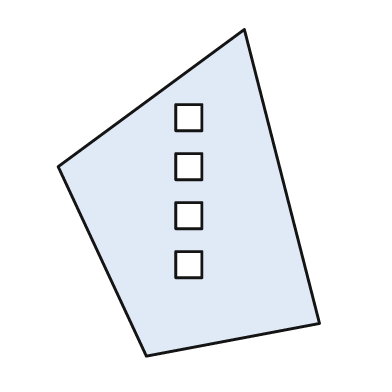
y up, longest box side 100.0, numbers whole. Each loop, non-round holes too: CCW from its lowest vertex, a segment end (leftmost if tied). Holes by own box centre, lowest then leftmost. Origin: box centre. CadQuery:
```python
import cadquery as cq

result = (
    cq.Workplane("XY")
    .moveTo(-13.0, -50.0)
    .lineTo(40.0, -40.0)
    .lineTo(17.0, 50.0)
    .lineTo(-40.0, 8.0)
    .close()
    .moveTo(-4.0, -26.0)
    .lineTo(4.0, -26.0)
    .lineTo(4.0, -18.0)
    .lineTo(-4.0, -18.0)
    .close()
    .moveTo(-4.0, -11.0)
    .lineTo(4.0, -11.0)
    .lineTo(4.0, -3.0)
    .lineTo(-4.0, -3.0)
    .close()
    .moveTo(-4.0, 4.0)
    .lineTo(4.0, 4.0)
    .lineTo(4.0, 12.0)
    .lineTo(-4.0, 12.0)
    .close()
    .moveTo(-4.0, 19.0)
    .lineTo(4.0, 19.0)
    .lineTo(4.0, 27.0)
    .lineTo(-4.0, 27.0)
    .close()
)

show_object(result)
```